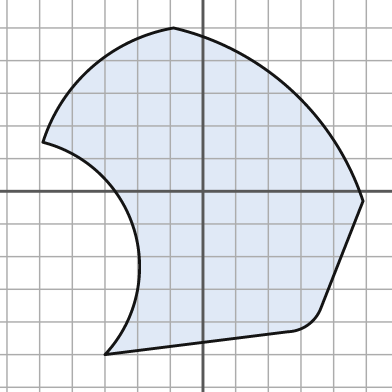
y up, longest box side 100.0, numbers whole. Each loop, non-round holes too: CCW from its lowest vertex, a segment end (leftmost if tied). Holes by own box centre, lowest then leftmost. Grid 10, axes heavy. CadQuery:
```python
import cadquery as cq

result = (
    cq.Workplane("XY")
    .moveTo(-30.0, -50.0)
    .lineTo(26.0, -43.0)
    .threePointArc((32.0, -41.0), (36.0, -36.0))
    .lineTo(49.0, -3.0)
    .threePointArc((27.0, 31.0), (-9.0, 50.0))
    .threePointArc((-34.0, 38.0), (-49.0, 15.0))
    .threePointArc((-21.0, -12.0), (-30.0, -50.0))
    .close()
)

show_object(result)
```